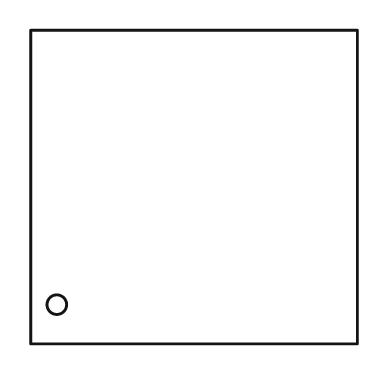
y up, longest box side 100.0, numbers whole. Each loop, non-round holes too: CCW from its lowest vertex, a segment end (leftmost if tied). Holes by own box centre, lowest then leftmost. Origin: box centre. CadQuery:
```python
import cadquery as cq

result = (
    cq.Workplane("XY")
    .moveTo(-50.0, -48.0)
    .lineTo(50.0, -48.0)
    .lineTo(50.0, 48.0)
    .lineTo(-50.0, 48.0)
    .close()
    .moveTo(-42.0, -36.0)
    .circle(3.0)
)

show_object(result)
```